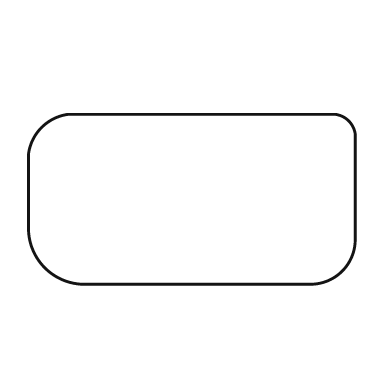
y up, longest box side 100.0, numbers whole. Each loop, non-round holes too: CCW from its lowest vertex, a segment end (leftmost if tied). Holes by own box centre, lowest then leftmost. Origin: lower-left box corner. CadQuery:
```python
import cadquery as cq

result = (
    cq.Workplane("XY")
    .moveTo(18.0, 0.0)
    .lineTo(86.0, 0.0)
    .threePointArc((96.0, 4.0), (100.0, 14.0))
    .lineTo(100.0, 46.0)
    .threePointArc((98.0, 50.0), (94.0, 52.0))
    .lineTo(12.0, 52.0)
    .threePointArc((4.0, 48.0), (0.0, 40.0))
    .lineTo(0.0, 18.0)
    .threePointArc((5.0, 5.0), (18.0, 0.0))
    .close()
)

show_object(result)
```